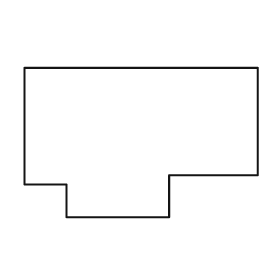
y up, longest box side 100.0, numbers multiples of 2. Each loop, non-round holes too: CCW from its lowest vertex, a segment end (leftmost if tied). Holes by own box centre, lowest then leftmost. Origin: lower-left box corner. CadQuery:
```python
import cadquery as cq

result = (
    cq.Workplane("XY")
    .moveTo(18.0, 0.0)
    .lineTo(62.0, 0.0)
    .lineTo(62.0, 18.0)
    .lineTo(100.0, 18.0)
    .lineTo(100.0, 64.0)
    .lineTo(0.0, 64.0)
    .lineTo(0.0, 14.0)
    .lineTo(18.0, 14.0)
    .close()
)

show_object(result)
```